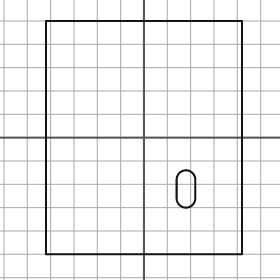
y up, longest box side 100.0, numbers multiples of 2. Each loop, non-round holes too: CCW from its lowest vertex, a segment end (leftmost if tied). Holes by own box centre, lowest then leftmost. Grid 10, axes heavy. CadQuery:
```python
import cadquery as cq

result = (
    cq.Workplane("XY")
    .moveTo(-42.0, -50.0)
    .lineTo(42.0, -50.0)
    .lineTo(42.0, 50.0)
    .lineTo(-42.0, 50.0)
    .close()
    .moveTo(14.0, -26.0)
    .threePointArc((18.0, -30.0), (22.0, -26.0))
    .lineTo(22.0, -18.0)
    .threePointArc((18.0, -14.0), (14.0, -18.0))
    .close()
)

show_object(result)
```